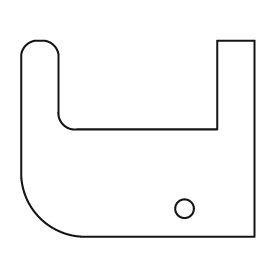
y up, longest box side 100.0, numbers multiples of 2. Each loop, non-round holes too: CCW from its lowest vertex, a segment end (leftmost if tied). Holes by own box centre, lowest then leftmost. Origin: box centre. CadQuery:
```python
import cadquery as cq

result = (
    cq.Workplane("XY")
    .moveTo(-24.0, -42.0)
    .lineTo(50.0, -42.0)
    .lineTo(50.0, 42.0)
    .lineTo(34.0, 42.0)
    .lineTo(34.0, 4.0)
    .lineTo(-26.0, 4.0)
    .threePointArc((-32.0, 6.0), (-34.0, 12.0))
    .lineTo(-34.0, 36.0)
    .threePointArc((-36.0, 40.0), (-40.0, 42.0))
    .lineTo(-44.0, 42.0)
    .threePointArc((-48.0, 40.0), (-50.0, 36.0))
    .lineTo(-50.0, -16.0)
    .threePointArc((-42.0, -34.0), (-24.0, -42.0))
    .close()
    .moveTo(20.0, -30.0)
    .circle(4.0)
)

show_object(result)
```